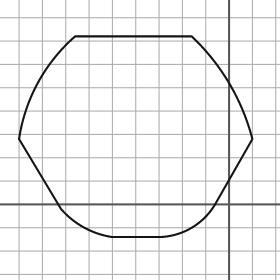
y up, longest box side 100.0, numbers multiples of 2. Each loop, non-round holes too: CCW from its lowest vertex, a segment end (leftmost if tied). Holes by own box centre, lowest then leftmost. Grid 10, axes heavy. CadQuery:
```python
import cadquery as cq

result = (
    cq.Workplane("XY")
    .moveTo(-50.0, -14.0)
    .lineTo(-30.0, -14.0)
    .threePointArc((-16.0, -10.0), (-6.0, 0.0))
    .lineTo(10.0, 28.0)
    .threePointArc((0.0, 52.0), (-16.0, 72.0))
    .lineTo(-66.0, 72.0)
    .threePointArc((-82.0, 52.0), (-90.0, 28.0))
    .lineTo(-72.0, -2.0)
    .threePointArc((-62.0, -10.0), (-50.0, -14.0))
    .close()
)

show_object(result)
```